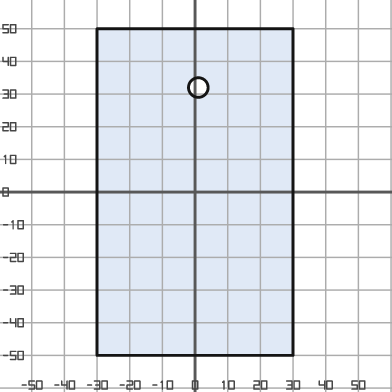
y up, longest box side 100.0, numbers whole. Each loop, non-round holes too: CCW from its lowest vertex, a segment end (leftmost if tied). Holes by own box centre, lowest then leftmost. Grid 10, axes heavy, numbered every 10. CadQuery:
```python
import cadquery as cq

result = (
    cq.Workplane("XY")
    .moveTo(-30.0, -50.0)
    .lineTo(30.0, -50.0)
    .lineTo(30.0, 50.0)
    .lineTo(-30.0, 50.0)
    .close()
    .moveTo(1.0, 32.0)
    .circle(3.0)
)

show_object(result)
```